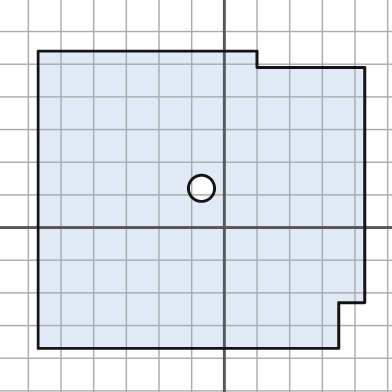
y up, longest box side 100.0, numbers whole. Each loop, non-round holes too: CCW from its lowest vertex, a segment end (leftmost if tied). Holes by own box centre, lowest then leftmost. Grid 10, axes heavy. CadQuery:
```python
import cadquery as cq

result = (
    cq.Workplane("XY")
    .moveTo(-57.0, -37.0)
    .lineTo(35.0, -37.0)
    .lineTo(35.0, -23.0)
    .lineTo(43.0, -23.0)
    .lineTo(43.0, 49.0)
    .lineTo(10.0, 49.0)
    .lineTo(10.0, 54.0)
    .lineTo(-57.0, 54.0)
    .close()
    .moveTo(-7.0, 12.0)
    .circle(4.0)
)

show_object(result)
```